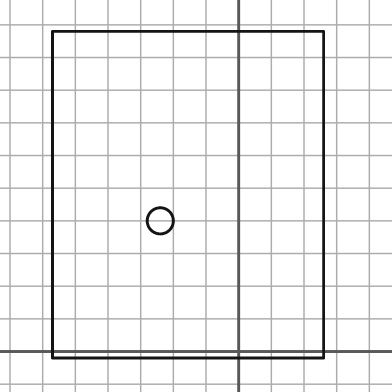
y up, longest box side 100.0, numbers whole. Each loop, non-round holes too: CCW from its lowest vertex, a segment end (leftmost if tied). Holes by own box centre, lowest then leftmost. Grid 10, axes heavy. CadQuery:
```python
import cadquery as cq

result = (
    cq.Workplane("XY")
    .moveTo(-57.0, -2.0)
    .lineTo(26.0, -2.0)
    .lineTo(26.0, 98.0)
    .lineTo(-57.0, 98.0)
    .close()
    .moveTo(-24.0, 40.0)
    .circle(4.0)
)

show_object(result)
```